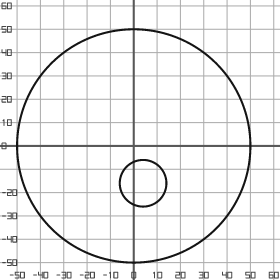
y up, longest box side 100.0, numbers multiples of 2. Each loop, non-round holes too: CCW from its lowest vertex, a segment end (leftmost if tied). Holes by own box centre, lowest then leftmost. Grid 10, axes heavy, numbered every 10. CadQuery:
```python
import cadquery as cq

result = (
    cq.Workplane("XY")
    .moveTo(0.0, 0.0)
    .circle(50.0)
    .moveTo(4.0, -16.0)
    .circle(10.0)
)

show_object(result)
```